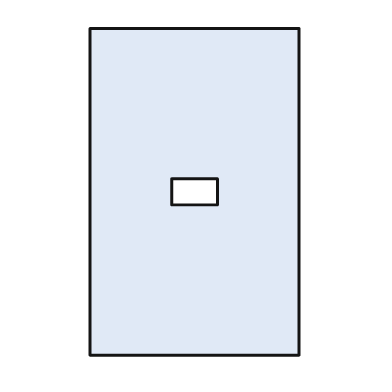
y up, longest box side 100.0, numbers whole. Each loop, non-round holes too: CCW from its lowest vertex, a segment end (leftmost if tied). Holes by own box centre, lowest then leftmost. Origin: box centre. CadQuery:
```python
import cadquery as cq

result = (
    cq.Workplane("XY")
    .moveTo(-32.0, -50.0)
    .lineTo(32.0, -50.0)
    .lineTo(32.0, 50.0)
    .lineTo(-32.0, 50.0)
    .close()
    .moveTo(-7.0, -4.0)
    .lineTo(7.0, -4.0)
    .lineTo(7.0, 4.0)
    .lineTo(-7.0, 4.0)
    .close()
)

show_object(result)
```